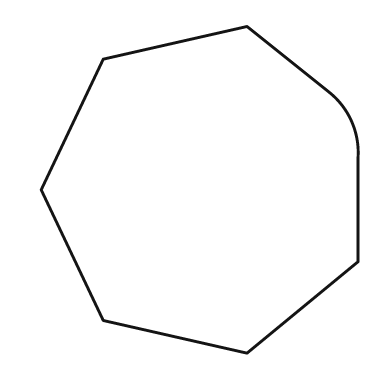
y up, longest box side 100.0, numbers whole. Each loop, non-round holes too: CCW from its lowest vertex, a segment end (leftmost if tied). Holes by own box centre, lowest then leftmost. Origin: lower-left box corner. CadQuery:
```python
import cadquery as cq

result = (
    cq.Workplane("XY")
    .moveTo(63.0, 0.0)
    .lineTo(97.0, 28.0)
    .lineTo(97.0, 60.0)
    .threePointArc((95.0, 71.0), (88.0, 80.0))
    .lineTo(63.0, 100.0)
    .lineTo(19.0, 90.0)
    .lineTo(0.0, 50.0)
    .lineTo(19.0, 10.0)
    .close()
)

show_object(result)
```